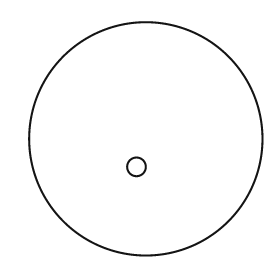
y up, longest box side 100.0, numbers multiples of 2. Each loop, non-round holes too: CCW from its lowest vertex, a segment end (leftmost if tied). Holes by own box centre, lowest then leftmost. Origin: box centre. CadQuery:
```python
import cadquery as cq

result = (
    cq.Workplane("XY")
    .moveTo(0.0, 0.0)
    .circle(50.0)
    .moveTo(-4.0, -12.0)
    .circle(4.0)
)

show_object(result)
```